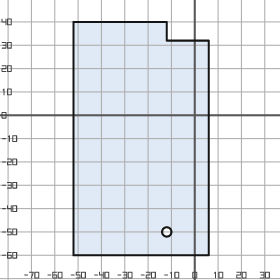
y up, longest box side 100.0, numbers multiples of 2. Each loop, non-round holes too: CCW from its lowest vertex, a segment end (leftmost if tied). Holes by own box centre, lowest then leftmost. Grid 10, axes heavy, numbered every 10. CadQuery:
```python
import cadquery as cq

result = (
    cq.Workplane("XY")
    .moveTo(-52.0, -60.0)
    .lineTo(6.0, -60.0)
    .lineTo(6.0, 32.0)
    .lineTo(-12.0, 32.0)
    .lineTo(-12.0, 40.0)
    .lineTo(-52.0, 40.0)
    .close()
    .moveTo(-12.0, -50.0)
    .circle(2.0)
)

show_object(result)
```